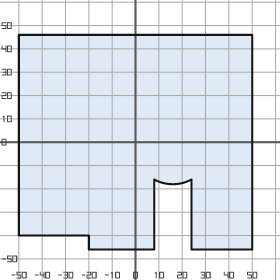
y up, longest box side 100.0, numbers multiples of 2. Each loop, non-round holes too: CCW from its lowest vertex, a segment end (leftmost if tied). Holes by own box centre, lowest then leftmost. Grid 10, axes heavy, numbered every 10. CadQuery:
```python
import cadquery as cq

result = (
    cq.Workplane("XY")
    .moveTo(-20.0, -46.0)
    .lineTo(8.0, -46.0)
    .lineTo(8.0, -16.0)
    .threePointArc((16.0, -18.0), (24.0, -16.0))
    .lineTo(24.0, -46.0)
    .lineTo(50.0, -46.0)
    .lineTo(50.0, 46.0)
    .lineTo(-50.0, 46.0)
    .lineTo(-50.0, -40.0)
    .lineTo(-20.0, -40.0)
    .close()
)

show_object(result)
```